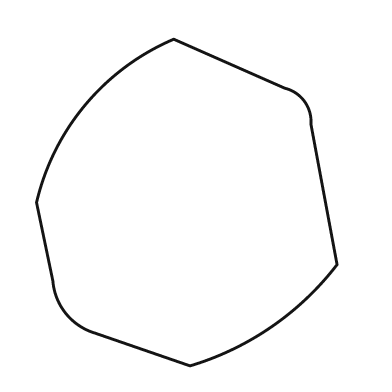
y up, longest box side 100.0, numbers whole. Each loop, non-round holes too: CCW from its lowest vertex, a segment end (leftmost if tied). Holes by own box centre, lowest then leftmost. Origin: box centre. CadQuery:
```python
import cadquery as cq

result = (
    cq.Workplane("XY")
    .moveTo(1.0, -50.0)
    .threePointArc((26.0, -38.0), (46.0, -19.0))
    .lineTo(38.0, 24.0)
    .threePointArc((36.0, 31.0), (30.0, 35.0))
    .lineTo(-4.0, 50.0)
    .threePointArc((-31.0, 30.0), (-46.0, 0.0))
    .lineTo(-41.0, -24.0)
    .threePointArc((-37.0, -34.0), (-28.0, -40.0))
    .close()
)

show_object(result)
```